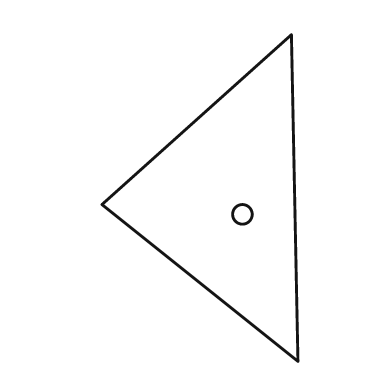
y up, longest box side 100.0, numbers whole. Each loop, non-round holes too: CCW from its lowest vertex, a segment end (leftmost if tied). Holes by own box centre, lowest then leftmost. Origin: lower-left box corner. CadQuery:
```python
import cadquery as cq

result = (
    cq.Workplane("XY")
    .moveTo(60.0, 0.0)
    .lineTo(58.0, 100.0)
    .lineTo(0.0, 48.0)
    .close()
    .moveTo(43.0, 45.0)
    .circle(3.0)
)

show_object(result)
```